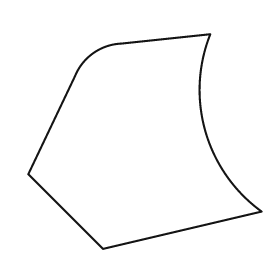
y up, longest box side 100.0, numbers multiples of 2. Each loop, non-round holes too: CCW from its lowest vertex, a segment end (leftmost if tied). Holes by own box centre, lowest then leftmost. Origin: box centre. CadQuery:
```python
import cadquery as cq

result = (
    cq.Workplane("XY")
    .moveTo(-18.0, -46.0)
    .lineTo(50.0, -30.0)
    .threePointArc((26.0, 4.0), (28.0, 46.0))
    .lineTo(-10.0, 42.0)
    .threePointArc((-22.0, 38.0), (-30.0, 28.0))
    .lineTo(-50.0, -14.0)
    .close()
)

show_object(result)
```